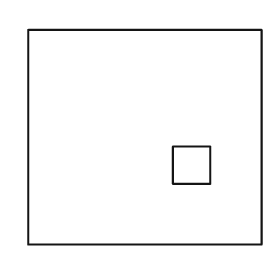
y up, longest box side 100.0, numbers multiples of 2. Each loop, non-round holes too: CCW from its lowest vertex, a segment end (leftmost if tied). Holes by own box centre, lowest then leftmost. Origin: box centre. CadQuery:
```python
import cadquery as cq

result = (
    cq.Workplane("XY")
    .moveTo(-50.0, -46.0)
    .lineTo(50.0, -46.0)
    .lineTo(50.0, 46.0)
    .lineTo(-50.0, 46.0)
    .close()
    .moveTo(12.0, -20.0)
    .lineTo(28.0, -20.0)
    .lineTo(28.0, -4.0)
    .lineTo(12.0, -4.0)
    .close()
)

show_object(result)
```